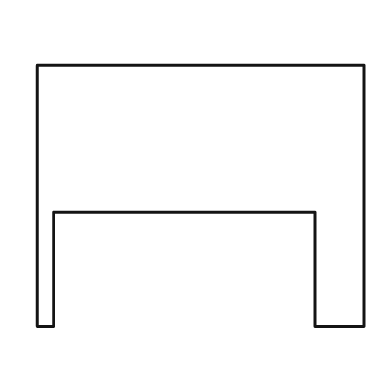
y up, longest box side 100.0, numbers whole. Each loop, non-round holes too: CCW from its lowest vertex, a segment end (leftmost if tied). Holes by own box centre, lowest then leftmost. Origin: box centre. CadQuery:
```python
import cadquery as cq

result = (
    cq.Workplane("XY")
    .moveTo(-50.0, -40.0)
    .lineTo(-45.0, -40.0)
    .lineTo(-45.0, -5.0)
    .lineTo(35.0, -5.0)
    .lineTo(35.0, -40.0)
    .lineTo(50.0, -40.0)
    .lineTo(50.0, 40.0)
    .lineTo(-50.0, 40.0)
    .close()
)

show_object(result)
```